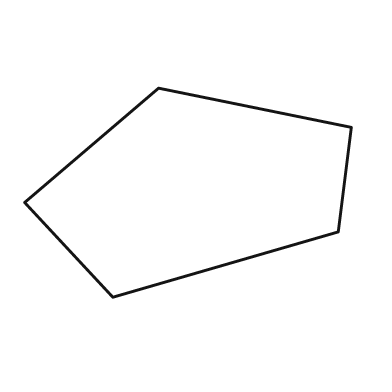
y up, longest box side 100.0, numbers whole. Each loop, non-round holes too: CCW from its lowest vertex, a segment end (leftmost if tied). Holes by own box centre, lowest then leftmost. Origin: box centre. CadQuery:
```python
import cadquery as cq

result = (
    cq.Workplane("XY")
    .moveTo(-23.0, -32.0)
    .lineTo(46.0, -12.0)
    .lineTo(50.0, 20.0)
    .lineTo(-9.0, 32.0)
    .lineTo(-50.0, -3.0)
    .close()
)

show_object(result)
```